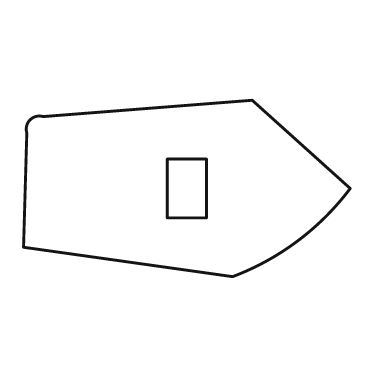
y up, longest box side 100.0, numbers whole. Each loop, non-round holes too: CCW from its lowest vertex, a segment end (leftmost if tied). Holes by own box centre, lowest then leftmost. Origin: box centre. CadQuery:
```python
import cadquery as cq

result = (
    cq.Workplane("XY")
    .moveTo(14.0, -27.0)
    .threePointArc((34.0, -16.0), (50.0, 0.0))
    .lineTo(20.0, 27.0)
    .lineTo(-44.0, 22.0)
    .threePointArc((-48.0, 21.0), (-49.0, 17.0))
    .lineTo(-50.0, -18.0)
    .close()
    .moveTo(-6.0, -9.0)
    .lineTo(6.0, -9.0)
    .lineTo(6.0, 9.0)
    .lineTo(-6.0, 9.0)
    .close()
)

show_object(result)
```